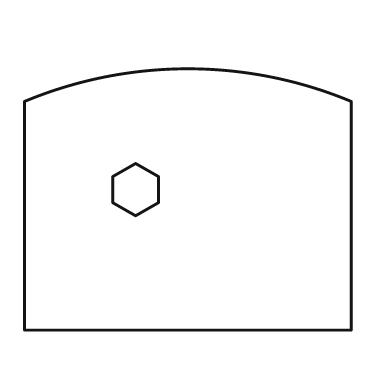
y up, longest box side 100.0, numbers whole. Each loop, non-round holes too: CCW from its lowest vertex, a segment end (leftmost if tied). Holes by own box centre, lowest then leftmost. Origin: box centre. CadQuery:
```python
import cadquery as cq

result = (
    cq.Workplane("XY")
    .moveTo(-50.0, -40.0)
    .lineTo(50.0, -40.0)
    .lineTo(50.0, 30.0)
    .threePointArc((0.0, 40.0), (-50.0, 30.0))
    .close()
    .moveTo(-16.0, -5.0)
    .lineTo(-9.0, -1.0)
    .lineTo(-9.0, 7.0)
    .lineTo(-16.0, 11.0)
    .lineTo(-23.0, 7.0)
    .lineTo(-23.0, -1.0)
    .close()
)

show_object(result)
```